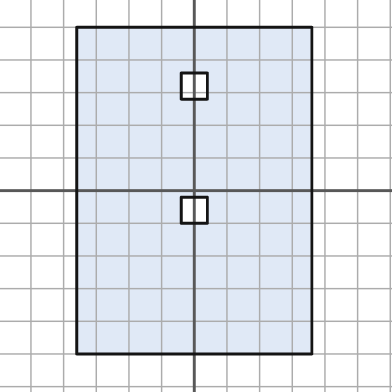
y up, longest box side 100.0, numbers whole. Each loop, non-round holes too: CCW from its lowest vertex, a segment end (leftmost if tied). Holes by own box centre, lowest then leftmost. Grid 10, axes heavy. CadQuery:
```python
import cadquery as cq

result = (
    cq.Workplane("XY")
    .moveTo(-36.0, -50.0)
    .lineTo(36.0, -50.0)
    .lineTo(36.0, 50.0)
    .lineTo(-36.0, 50.0)
    .close()
    .moveTo(-4.0, -10.0)
    .lineTo(4.0, -10.0)
    .lineTo(4.0, -2.0)
    .lineTo(-4.0, -2.0)
    .close()
    .moveTo(-4.0, 28.0)
    .lineTo(4.0, 28.0)
    .lineTo(4.0, 36.0)
    .lineTo(-4.0, 36.0)
    .close()
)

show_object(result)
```